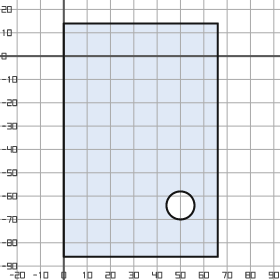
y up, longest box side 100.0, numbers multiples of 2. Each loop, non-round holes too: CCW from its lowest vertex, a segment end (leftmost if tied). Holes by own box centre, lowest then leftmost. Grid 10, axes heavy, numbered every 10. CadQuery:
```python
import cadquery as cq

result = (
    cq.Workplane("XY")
    .moveTo(0.0, -86.0)
    .lineTo(66.0, -86.0)
    .lineTo(66.0, 14.0)
    .lineTo(0.0, 14.0)
    .close()
    .moveTo(50.0, -64.0)
    .circle(6.0)
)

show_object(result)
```